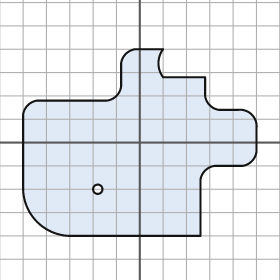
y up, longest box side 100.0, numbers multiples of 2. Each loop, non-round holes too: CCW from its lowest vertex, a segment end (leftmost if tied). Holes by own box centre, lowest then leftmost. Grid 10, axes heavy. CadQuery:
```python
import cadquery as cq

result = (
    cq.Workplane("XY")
    .moveTo(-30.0, -40.0)
    .lineTo(26.0, -40.0)
    .lineTo(26.0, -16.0)
    .threePointArc((28.0, -12.0), (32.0, -10.0))
    .lineTo(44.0, -10.0)
    .threePointArc((48.0, -8.0), (50.0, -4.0))
    .lineTo(50.0, 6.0)
    .threePointArc((48.0, 12.0), (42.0, 14.0))
    .lineTo(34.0, 14.0)
    .threePointArc((30.0, 16.0), (28.0, 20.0))
    .lineTo(28.0, 28.0)
    .lineTo(10.0, 28.0)
    .threePointArc((8.0, 34.0), (10.0, 40.0))
    .lineTo(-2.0, 40.0)
    .threePointArc((-6.0, 38.0), (-8.0, 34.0))
    .lineTo(-8.0, 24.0)
    .threePointArc((-10.0, 20.0), (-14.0, 18.0))
    .lineTo(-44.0, 18.0)
    .threePointArc((-48.0, 16.0), (-50.0, 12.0))
    .lineTo(-50.0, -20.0)
    .threePointArc((-44.0, -34.0), (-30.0, -40.0))
    .close()
    .moveTo(-18.0, -20.0)
    .circle(2.0)
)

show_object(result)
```